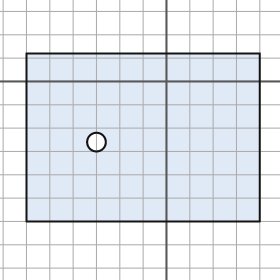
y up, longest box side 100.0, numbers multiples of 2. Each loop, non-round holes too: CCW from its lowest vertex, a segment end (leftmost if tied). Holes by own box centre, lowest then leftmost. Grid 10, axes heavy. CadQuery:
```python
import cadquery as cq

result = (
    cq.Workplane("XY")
    .moveTo(-60.0, -60.0)
    .lineTo(40.0, -60.0)
    .lineTo(40.0, 12.0)
    .lineTo(-60.0, 12.0)
    .close()
    .moveTo(-30.0, -26.0)
    .circle(4.0)
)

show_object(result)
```